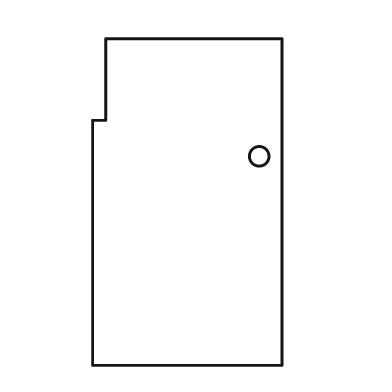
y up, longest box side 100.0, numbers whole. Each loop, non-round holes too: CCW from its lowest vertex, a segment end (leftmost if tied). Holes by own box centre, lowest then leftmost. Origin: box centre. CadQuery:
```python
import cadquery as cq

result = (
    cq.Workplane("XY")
    .moveTo(-29.0, -50.0)
    .lineTo(29.0, -50.0)
    .lineTo(29.0, 50.0)
    .lineTo(-25.0, 50.0)
    .lineTo(-25.0, 25.0)
    .lineTo(-29.0, 25.0)
    .close()
    .moveTo(22.0, 14.0)
    .circle(3.0)
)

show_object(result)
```